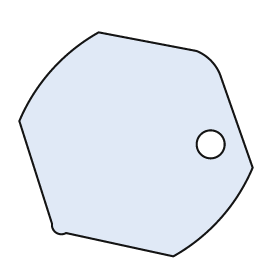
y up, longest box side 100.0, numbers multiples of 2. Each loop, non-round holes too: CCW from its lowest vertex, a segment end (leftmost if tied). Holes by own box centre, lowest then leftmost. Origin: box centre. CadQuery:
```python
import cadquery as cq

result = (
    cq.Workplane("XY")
    .moveTo(16.0, -48.0)
    .threePointArc((36.0, -32.0), (50.0, -10.0))
    .lineTo(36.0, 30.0)
    .threePointArc((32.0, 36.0), (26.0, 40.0))
    .lineTo(-16.0, 48.0)
    .threePointArc((-36.0, 32.0), (-50.0, 10.0))
    .lineTo(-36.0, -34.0)
    .threePointArc((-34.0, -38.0), (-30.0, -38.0))
    .close()
    .moveTo(32.0, 0.0)
    .circle(6.0)
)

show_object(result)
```